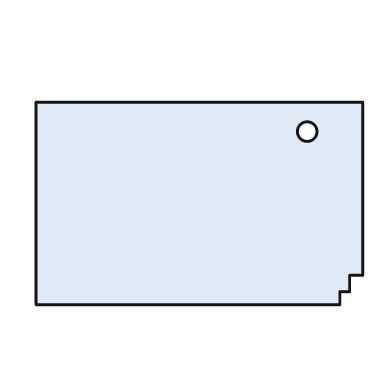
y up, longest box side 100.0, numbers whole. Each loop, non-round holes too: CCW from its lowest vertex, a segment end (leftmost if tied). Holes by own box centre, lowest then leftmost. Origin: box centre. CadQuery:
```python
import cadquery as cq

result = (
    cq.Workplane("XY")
    .moveTo(-50.0, -31.0)
    .lineTo(43.0, -31.0)
    .lineTo(43.0, -27.0)
    .lineTo(46.0, -27.0)
    .lineTo(46.0, -22.0)
    .lineTo(50.0, -22.0)
    .lineTo(50.0, 31.0)
    .lineTo(-50.0, 31.0)
    .close()
    .moveTo(33.0, 22.0)
    .circle(3.0)
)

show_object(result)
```